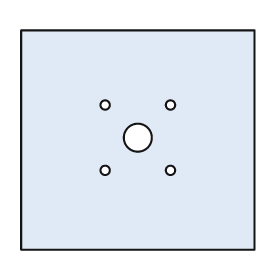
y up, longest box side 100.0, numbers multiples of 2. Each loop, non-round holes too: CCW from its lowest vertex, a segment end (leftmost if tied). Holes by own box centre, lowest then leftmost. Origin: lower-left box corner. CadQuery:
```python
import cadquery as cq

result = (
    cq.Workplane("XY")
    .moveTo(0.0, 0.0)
    .lineTo(100.0, 0.0)
    .lineTo(100.0, 94.0)
    .lineTo(0.0, 94.0)
    .close()
    .moveTo(36.0, 34.0)
    .circle(2.0)
    .moveTo(64.0, 34.0)
    .circle(2.0)
    .moveTo(50.0, 48.0)
    .circle(6.0)
    .moveTo(36.0, 62.0)
    .circle(2.0)
    .moveTo(64.0, 62.0)
    .circle(2.0)
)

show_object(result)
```